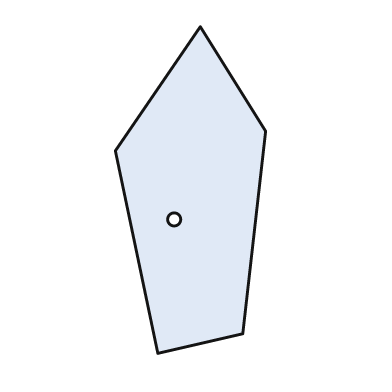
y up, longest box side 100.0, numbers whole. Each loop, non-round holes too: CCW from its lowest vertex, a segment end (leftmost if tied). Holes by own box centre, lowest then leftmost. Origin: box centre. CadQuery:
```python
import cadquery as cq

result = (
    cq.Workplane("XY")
    .moveTo(-10.0, -50.0)
    .lineTo(16.0, -44.0)
    .lineTo(23.0, 18.0)
    .lineTo(3.0, 50.0)
    .lineTo(-23.0, 12.0)
    .close()
    .moveTo(-5.0, -9.0)
    .circle(2.0)
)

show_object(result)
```